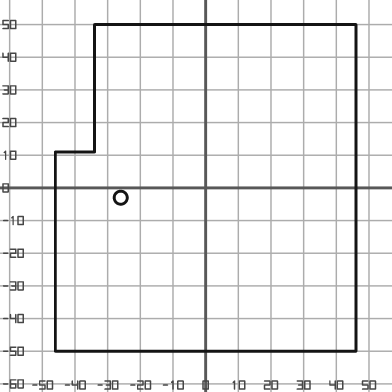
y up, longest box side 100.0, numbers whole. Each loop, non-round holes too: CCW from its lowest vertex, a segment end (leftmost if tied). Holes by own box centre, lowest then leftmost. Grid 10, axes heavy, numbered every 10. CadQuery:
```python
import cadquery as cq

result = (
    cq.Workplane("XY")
    .moveTo(-46.0, -50.0)
    .lineTo(46.0, -50.0)
    .lineTo(46.0, 50.0)
    .lineTo(-34.0, 50.0)
    .lineTo(-34.0, 11.0)
    .lineTo(-46.0, 11.0)
    .close()
    .moveTo(-26.0, -3.0)
    .circle(2.0)
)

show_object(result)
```